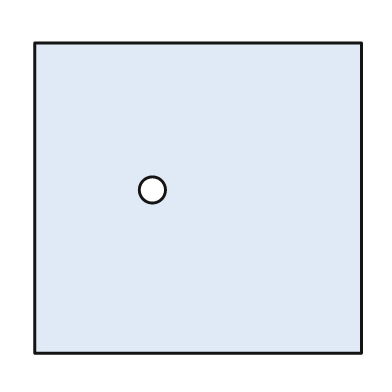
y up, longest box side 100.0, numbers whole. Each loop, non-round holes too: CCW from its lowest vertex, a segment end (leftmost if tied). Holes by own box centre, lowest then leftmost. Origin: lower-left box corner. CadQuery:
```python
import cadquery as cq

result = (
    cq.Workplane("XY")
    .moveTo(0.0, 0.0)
    .lineTo(100.0, 0.0)
    .lineTo(100.0, 95.0)
    .lineTo(0.0, 95.0)
    .close()
    .moveTo(36.0, 50.0)
    .circle(4.0)
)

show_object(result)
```